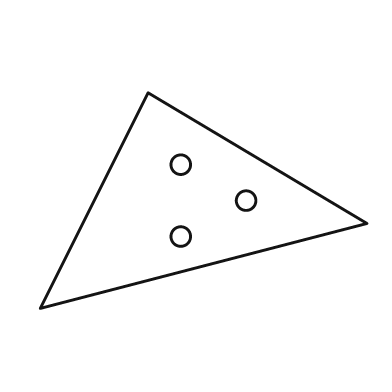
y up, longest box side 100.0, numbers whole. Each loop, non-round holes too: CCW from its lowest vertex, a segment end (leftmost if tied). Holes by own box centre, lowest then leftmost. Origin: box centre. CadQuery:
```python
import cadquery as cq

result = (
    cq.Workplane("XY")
    .moveTo(-50.0, -33.0)
    .lineTo(50.0, -7.0)
    .lineTo(-17.0, 33.0)
    .close()
    .moveTo(-7.0, -11.0)
    .circle(3.0)
    .moveTo(13.0, 0.0)
    .circle(3.0)
    .moveTo(-7.0, 11.0)
    .circle(3.0)
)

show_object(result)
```